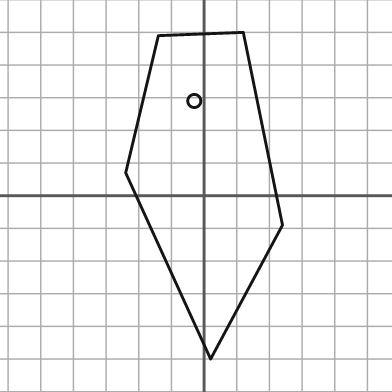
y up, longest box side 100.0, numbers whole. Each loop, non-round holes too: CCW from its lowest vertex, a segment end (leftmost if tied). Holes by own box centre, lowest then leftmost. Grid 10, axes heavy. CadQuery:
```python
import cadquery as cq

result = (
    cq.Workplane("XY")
    .moveTo(2.0, -50.0)
    .lineTo(24.0, -9.0)
    .lineTo(12.0, 50.0)
    .lineTo(-14.0, 49.0)
    .lineTo(-24.0, 7.0)
    .close()
    .moveTo(-3.0, 29.0)
    .circle(2.0)
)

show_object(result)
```